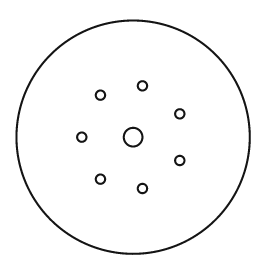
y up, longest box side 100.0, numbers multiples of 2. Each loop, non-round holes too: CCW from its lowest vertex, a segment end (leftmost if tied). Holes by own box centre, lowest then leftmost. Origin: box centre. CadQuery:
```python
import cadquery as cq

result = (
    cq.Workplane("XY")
    .moveTo(0.0, 0.0)
    .circle(50.0)
    .moveTo(4.0, -22.0)
    .circle(2.0)
    .moveTo(-14.0, -18.0)
    .circle(2.0)
    .moveTo(20.0, -10.0)
    .circle(2.0)
    .moveTo(-22.0, 0.0)
    .circle(2.0)
    .moveTo(0.0, 0.0)
    .circle(4.0)
    .moveTo(20.0, 10.0)
    .circle(2.0)
    .moveTo(-14.0, 18.0)
    .circle(2.0)
    .moveTo(4.0, 22.0)
    .circle(2.0)
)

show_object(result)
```